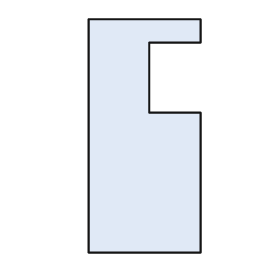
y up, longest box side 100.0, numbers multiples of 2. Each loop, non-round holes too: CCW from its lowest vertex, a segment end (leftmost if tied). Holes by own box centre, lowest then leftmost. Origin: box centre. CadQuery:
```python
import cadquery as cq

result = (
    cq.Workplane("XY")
    .moveTo(-24.0, -50.0)
    .lineTo(24.0, -50.0)
    .lineTo(24.0, 10.0)
    .lineTo(2.0, 10.0)
    .lineTo(2.0, 40.0)
    .lineTo(24.0, 40.0)
    .lineTo(24.0, 50.0)
    .lineTo(-24.0, 50.0)
    .close()
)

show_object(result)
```